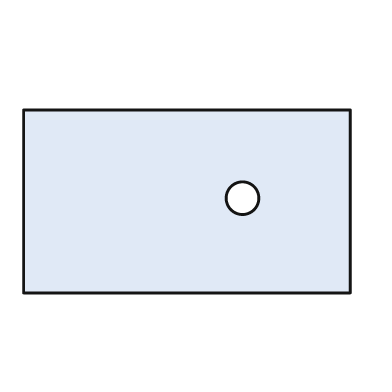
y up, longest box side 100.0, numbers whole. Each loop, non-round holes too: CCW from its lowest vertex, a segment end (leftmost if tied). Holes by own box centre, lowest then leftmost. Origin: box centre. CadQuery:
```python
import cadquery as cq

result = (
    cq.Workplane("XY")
    .moveTo(-50.0, -28.0)
    .lineTo(50.0, -28.0)
    .lineTo(50.0, 28.0)
    .lineTo(-50.0, 28.0)
    .close()
    .moveTo(17.0, 1.0)
    .circle(5.0)
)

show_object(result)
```